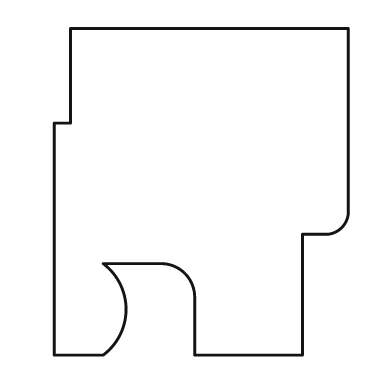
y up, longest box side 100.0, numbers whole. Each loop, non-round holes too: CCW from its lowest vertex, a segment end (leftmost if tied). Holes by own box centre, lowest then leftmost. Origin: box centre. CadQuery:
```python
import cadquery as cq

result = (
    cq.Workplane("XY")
    .moveTo(-45.0, -50.0)
    .lineTo(-30.0, -50.0)
    .threePointArc((-23.0, -36.0), (-30.0, -22.0))
    .lineTo(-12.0, -22.0)
    .threePointArc((-5.0, -25.0), (-2.0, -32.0))
    .lineTo(-2.0, -50.0)
    .lineTo(31.0, -50.0)
    .lineTo(31.0, -13.0)
    .lineTo(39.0, -13.0)
    .threePointArc((43.0, -11.0), (45.0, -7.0))
    .lineTo(45.0, 50.0)
    .lineTo(-40.0, 50.0)
    .lineTo(-40.0, 21.0)
    .lineTo(-45.0, 21.0)
    .close()
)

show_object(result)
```